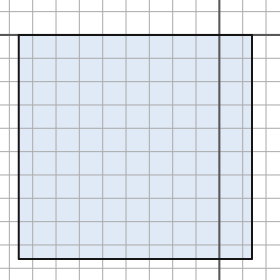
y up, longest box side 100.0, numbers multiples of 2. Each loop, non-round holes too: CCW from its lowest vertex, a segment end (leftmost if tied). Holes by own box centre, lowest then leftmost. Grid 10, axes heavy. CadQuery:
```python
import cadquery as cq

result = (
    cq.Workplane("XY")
    .moveTo(-86.0, -96.0)
    .lineTo(14.0, -96.0)
    .lineTo(14.0, 0.0)
    .lineTo(-86.0, 0.0)
    .close()
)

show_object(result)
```